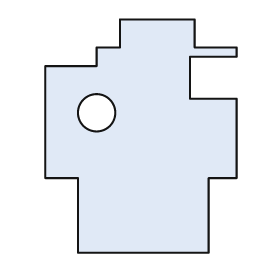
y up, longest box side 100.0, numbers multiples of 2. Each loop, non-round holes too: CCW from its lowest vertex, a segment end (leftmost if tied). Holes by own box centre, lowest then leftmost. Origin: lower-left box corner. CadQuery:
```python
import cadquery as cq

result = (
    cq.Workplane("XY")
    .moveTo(14.0, 0.0)
    .lineTo(70.0, 0.0)
    .lineTo(70.0, 32.0)
    .lineTo(82.0, 32.0)
    .lineTo(82.0, 66.0)
    .lineTo(62.0, 66.0)
    .lineTo(62.0, 84.0)
    .lineTo(82.0, 84.0)
    .lineTo(82.0, 88.0)
    .lineTo(64.0, 88.0)
    .lineTo(64.0, 100.0)
    .lineTo(32.0, 100.0)
    .lineTo(32.0, 88.0)
    .lineTo(22.0, 88.0)
    .lineTo(22.0, 80.0)
    .lineTo(0.0, 80.0)
    .lineTo(0.0, 32.0)
    .lineTo(14.0, 32.0)
    .close()
    .moveTo(22.0, 60.0)
    .circle(8.0)
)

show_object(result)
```